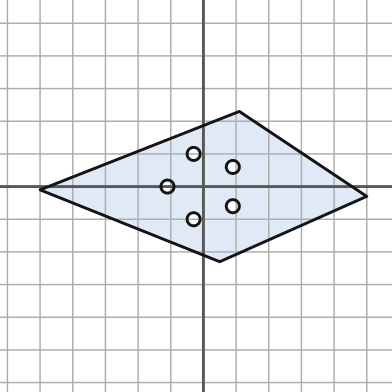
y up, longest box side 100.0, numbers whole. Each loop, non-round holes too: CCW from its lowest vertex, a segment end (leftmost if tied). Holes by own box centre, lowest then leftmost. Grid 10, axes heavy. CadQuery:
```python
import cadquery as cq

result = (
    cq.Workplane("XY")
    .moveTo(5.0, -23.0)
    .lineTo(50.0, -3.0)
    .lineTo(11.0, 23.0)
    .lineTo(-50.0, -1.0)
    .close()
    .moveTo(-3.0, -10.0)
    .circle(2.0)
    .moveTo(9.0, -6.0)
    .circle(2.0)
    .moveTo(-11.0, 0.0)
    .circle(2.0)
    .moveTo(9.0, 6.0)
    .circle(2.0)
    .moveTo(-3.0, 10.0)
    .circle(2.0)
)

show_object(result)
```